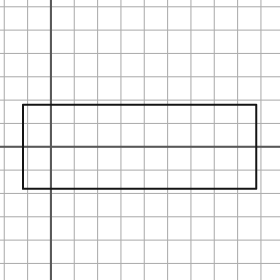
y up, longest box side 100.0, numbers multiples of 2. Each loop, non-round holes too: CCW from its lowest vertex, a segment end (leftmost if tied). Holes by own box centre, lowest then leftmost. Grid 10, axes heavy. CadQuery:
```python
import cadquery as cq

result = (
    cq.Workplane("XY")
    .moveTo(-12.0, -18.0)
    .lineTo(88.0, -18.0)
    .lineTo(88.0, 18.0)
    .lineTo(-12.0, 18.0)
    .close()
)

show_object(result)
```